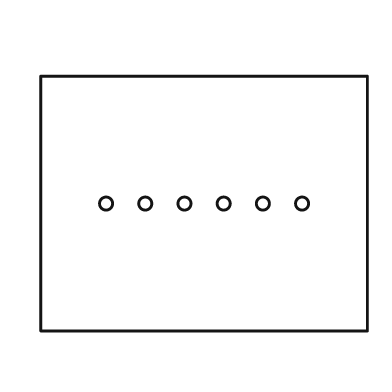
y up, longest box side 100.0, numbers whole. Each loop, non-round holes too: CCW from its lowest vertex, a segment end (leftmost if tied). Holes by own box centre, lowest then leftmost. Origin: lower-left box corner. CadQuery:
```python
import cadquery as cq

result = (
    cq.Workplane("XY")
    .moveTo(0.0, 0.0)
    .lineTo(100.0, 0.0)
    .lineTo(100.0, 78.0)
    .lineTo(0.0, 78.0)
    .close()
    .moveTo(20.0, 39.0)
    .circle(2.0)
    .moveTo(32.0, 39.0)
    .circle(2.0)
    .moveTo(44.0, 39.0)
    .circle(2.0)
    .moveTo(56.0, 39.0)
    .circle(2.0)
    .moveTo(68.0, 39.0)
    .circle(2.0)
    .moveTo(80.0, 39.0)
    .circle(2.0)
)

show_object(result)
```